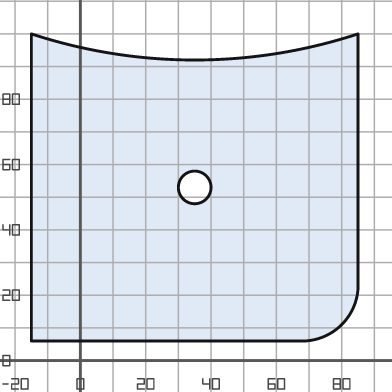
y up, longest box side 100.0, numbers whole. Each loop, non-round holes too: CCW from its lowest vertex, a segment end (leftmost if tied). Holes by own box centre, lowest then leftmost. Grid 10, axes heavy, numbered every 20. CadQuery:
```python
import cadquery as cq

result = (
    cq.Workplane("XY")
    .moveTo(-15.0, 6.0)
    .lineTo(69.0, 6.0)
    .threePointArc((80.0, 11.0), (85.0, 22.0))
    .lineTo(85.0, 100.0)
    .threePointArc((35.0, 92.0), (-15.0, 100.0))
    .close()
    .moveTo(35.0, 53.0)
    .circle(5.0)
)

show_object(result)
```